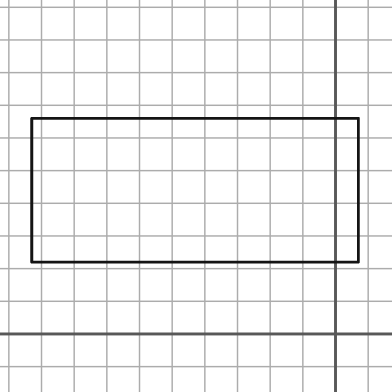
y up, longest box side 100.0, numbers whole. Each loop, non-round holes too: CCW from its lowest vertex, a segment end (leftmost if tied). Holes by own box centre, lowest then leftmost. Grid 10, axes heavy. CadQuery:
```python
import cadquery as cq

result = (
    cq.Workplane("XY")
    .moveTo(-93.0, 22.0)
    .lineTo(7.0, 22.0)
    .lineTo(7.0, 66.0)
    .lineTo(-93.0, 66.0)
    .close()
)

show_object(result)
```